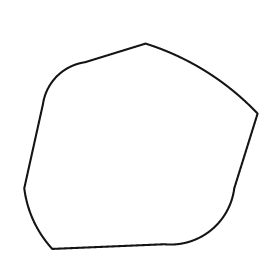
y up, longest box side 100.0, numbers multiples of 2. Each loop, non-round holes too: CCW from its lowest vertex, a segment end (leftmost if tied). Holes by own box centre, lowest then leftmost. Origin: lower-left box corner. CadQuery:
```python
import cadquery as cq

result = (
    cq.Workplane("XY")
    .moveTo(12.0, 0.0)
    .lineTo(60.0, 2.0)
    .threePointArc((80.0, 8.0), (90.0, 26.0))
    .lineTo(100.0, 58.0)
    .threePointArc((78.0, 76.0), (52.0, 88.0))
    .lineTo(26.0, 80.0)
    .threePointArc((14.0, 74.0), (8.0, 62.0))
    .lineTo(0.0, 26.0)
    .threePointArc((4.0, 12.0), (12.0, 0.0))
    .close()
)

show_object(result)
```